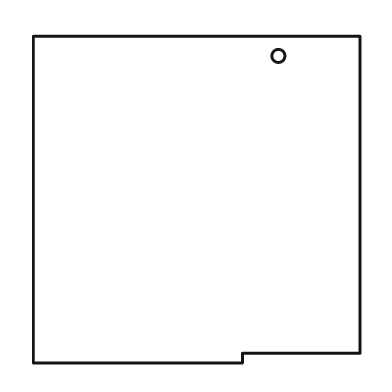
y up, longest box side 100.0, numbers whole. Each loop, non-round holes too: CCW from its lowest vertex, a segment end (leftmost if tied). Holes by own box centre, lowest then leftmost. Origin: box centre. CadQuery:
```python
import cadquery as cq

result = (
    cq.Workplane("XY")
    .moveTo(-50.0, -50.0)
    .lineTo(14.0, -50.0)
    .lineTo(14.0, -47.0)
    .lineTo(50.0, -47.0)
    .lineTo(50.0, 50.0)
    .lineTo(-50.0, 50.0)
    .close()
    .moveTo(25.0, 44.0)
    .circle(2.0)
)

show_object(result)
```